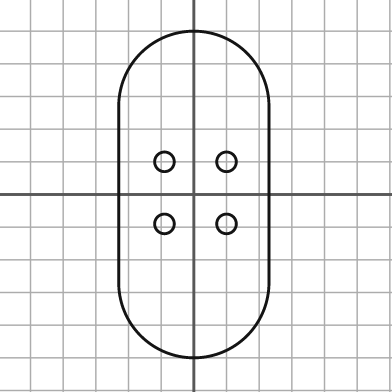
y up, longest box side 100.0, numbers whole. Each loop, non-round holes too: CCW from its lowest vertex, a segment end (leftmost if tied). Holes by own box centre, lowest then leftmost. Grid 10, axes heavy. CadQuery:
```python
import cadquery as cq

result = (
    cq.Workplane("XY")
    .moveTo(-23.0, -27.0)
    .threePointArc((0.0, -50.0), (23.0, -27.0))
    .lineTo(23.0, 27.0)
    .threePointArc((0.0, 50.0), (-23.0, 27.0))
    .close()
    .moveTo(-9.0, -9.0)
    .circle(3.0)
    .moveTo(10.0, -9.0)
    .circle(3.0)
    .moveTo(-9.0, 10.0)
    .circle(3.0)
    .moveTo(10.0, 10.0)
    .circle(3.0)
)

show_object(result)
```